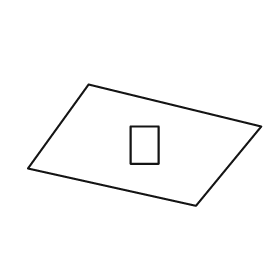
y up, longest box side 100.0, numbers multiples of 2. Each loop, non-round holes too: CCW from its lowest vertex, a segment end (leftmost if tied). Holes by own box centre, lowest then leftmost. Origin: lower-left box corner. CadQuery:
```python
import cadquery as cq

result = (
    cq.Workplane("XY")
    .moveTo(72.0, 0.0)
    .lineTo(100.0, 34.0)
    .lineTo(26.0, 52.0)
    .lineTo(0.0, 16.0)
    .close()
    .moveTo(44.0, 18.0)
    .lineTo(56.0, 18.0)
    .lineTo(56.0, 34.0)
    .lineTo(44.0, 34.0)
    .close()
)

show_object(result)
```